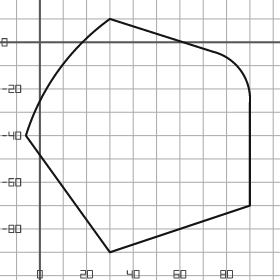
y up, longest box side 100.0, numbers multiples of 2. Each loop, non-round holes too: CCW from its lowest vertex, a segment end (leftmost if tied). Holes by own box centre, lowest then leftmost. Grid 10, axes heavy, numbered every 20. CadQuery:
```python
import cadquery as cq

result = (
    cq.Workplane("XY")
    .moveTo(30.0, -90.0)
    .lineTo(90.0, -70.0)
    .lineTo(90.0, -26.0)
    .threePointArc((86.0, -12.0), (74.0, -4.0))
    .lineTo(30.0, 10.0)
    .threePointArc((8.0, -12.0), (-6.0, -40.0))
    .close()
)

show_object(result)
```